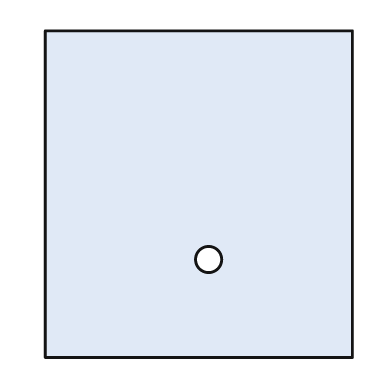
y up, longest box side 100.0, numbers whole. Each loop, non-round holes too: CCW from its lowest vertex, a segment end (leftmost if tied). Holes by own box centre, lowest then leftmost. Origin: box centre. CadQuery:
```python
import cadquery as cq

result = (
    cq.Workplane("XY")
    .moveTo(-47.0, -50.0)
    .lineTo(47.0, -50.0)
    .lineTo(47.0, 50.0)
    .lineTo(-47.0, 50.0)
    .close()
    .moveTo(3.0, -20.0)
    .circle(4.0)
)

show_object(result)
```